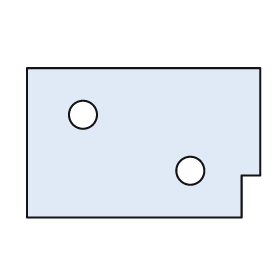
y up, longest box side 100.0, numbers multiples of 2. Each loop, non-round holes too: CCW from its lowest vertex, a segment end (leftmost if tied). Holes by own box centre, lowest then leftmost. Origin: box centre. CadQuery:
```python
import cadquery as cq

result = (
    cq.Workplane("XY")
    .moveTo(-50.0, -32.0)
    .lineTo(42.0, -32.0)
    .lineTo(42.0, -14.0)
    .lineTo(50.0, -14.0)
    .lineTo(50.0, 32.0)
    .lineTo(-50.0, 32.0)
    .close()
    .moveTo(20.0, -12.0)
    .circle(6.0)
    .moveTo(-26.0, 12.0)
    .circle(6.0)
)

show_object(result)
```